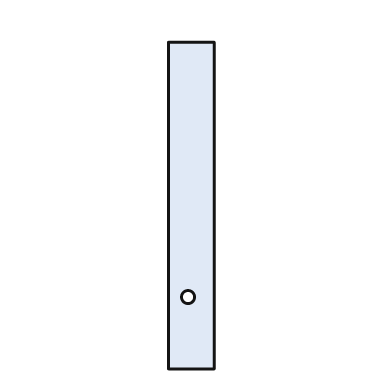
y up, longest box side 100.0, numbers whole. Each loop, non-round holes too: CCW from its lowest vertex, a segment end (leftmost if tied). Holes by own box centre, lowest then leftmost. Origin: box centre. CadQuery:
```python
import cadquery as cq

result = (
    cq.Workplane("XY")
    .moveTo(-7.0, -50.0)
    .lineTo(7.0, -50.0)
    .lineTo(7.0, 50.0)
    .lineTo(-7.0, 50.0)
    .close()
    .moveTo(-1.0, -28.0)
    .circle(2.0)
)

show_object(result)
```